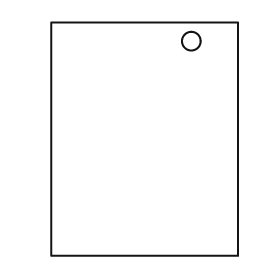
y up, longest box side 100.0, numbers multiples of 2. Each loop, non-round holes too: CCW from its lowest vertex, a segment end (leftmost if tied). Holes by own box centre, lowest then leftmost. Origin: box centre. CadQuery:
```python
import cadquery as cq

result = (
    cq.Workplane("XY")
    .moveTo(-40.0, -50.0)
    .lineTo(40.0, -50.0)
    .lineTo(40.0, 50.0)
    .lineTo(-40.0, 50.0)
    .close()
    .moveTo(20.0, 42.0)
    .circle(4.0)
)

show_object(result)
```